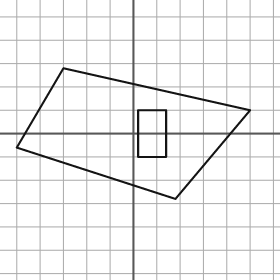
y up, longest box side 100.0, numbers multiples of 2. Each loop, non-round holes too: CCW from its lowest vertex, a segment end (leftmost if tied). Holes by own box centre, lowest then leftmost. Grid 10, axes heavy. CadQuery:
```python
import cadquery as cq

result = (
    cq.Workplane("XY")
    .moveTo(18.0, -28.0)
    .lineTo(50.0, 10.0)
    .lineTo(-30.0, 28.0)
    .lineTo(-50.0, -6.0)
    .close()
    .moveTo(2.0, -10.0)
    .lineTo(14.0, -10.0)
    .lineTo(14.0, 10.0)
    .lineTo(2.0, 10.0)
    .close()
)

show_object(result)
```